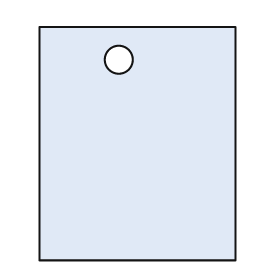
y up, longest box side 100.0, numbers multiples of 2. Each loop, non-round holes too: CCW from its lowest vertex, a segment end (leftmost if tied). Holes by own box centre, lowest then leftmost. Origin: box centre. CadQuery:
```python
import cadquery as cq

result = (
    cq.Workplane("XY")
    .moveTo(-42.0, -50.0)
    .lineTo(42.0, -50.0)
    .lineTo(42.0, 50.0)
    .lineTo(-42.0, 50.0)
    .close()
    .moveTo(-8.0, 36.0)
    .circle(6.0)
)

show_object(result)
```